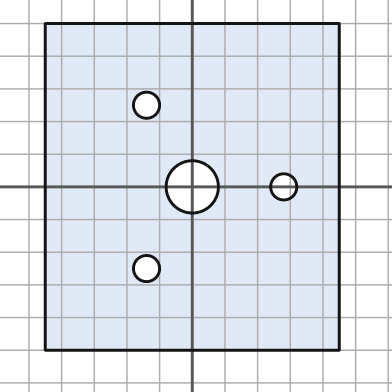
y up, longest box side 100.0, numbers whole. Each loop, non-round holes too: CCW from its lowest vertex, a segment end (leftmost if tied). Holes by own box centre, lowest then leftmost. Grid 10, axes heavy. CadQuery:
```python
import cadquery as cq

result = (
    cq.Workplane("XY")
    .moveTo(-45.0, -50.0)
    .lineTo(45.0, -50.0)
    .lineTo(45.0, 50.0)
    .lineTo(-45.0, 50.0)
    .close()
    .moveTo(-14.0, -25.0)
    .circle(4.0)
    .moveTo(0.0, 0.0)
    .circle(8.0)
    .moveTo(28.0, 0.0)
    .circle(4.0)
    .moveTo(-14.0, 25.0)
    .circle(4.0)
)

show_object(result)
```